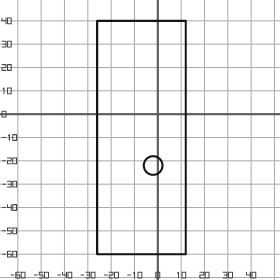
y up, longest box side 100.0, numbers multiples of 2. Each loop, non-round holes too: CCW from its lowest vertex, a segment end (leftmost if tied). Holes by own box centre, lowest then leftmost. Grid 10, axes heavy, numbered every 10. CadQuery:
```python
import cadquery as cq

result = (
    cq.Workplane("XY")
    .moveTo(-26.0, -60.0)
    .lineTo(12.0, -60.0)
    .lineTo(12.0, 40.0)
    .lineTo(-26.0, 40.0)
    .close()
    .moveTo(-2.0, -22.0)
    .circle(4.0)
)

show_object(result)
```